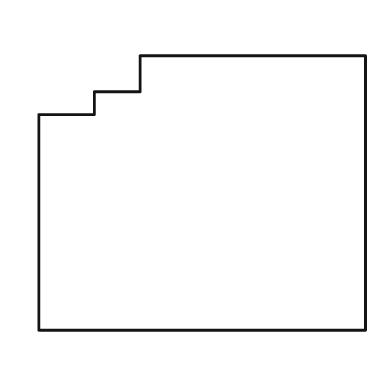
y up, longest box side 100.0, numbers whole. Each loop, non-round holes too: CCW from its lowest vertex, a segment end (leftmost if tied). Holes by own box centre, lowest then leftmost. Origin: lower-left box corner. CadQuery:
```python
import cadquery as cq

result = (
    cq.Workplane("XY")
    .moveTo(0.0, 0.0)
    .lineTo(100.0, 0.0)
    .lineTo(100.0, 84.0)
    .lineTo(31.0, 84.0)
    .lineTo(31.0, 73.0)
    .lineTo(17.0, 73.0)
    .lineTo(17.0, 66.0)
    .lineTo(0.0, 66.0)
    .close()
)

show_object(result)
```